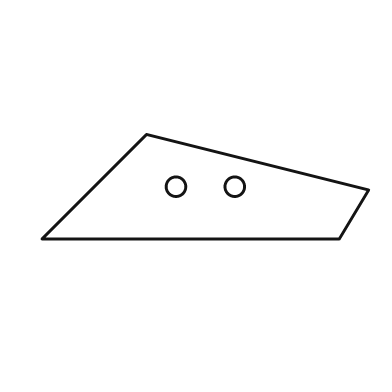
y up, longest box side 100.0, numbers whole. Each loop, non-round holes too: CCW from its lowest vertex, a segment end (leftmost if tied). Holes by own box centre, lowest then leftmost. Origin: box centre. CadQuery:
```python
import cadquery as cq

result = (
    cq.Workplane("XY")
    .moveTo(-50.0, -16.0)
    .lineTo(41.0, -16.0)
    .lineTo(50.0, -1.0)
    .lineTo(-18.0, 16.0)
    .close()
    .moveTo(-9.0, 0.0)
    .circle(3.0)
    .moveTo(9.0, 0.0)
    .circle(3.0)
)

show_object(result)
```